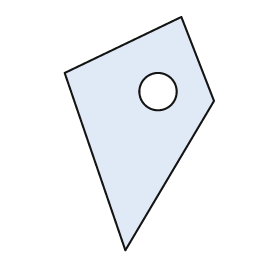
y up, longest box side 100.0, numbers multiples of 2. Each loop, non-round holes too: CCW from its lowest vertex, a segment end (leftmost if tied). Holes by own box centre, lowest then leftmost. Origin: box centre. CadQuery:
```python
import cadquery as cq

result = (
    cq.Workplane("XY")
    .moveTo(-6.0, -50.0)
    .lineTo(32.0, 14.0)
    .lineTo(18.0, 50.0)
    .lineTo(-32.0, 26.0)
    .close()
    .moveTo(8.0, 18.0)
    .circle(8.0)
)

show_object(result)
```